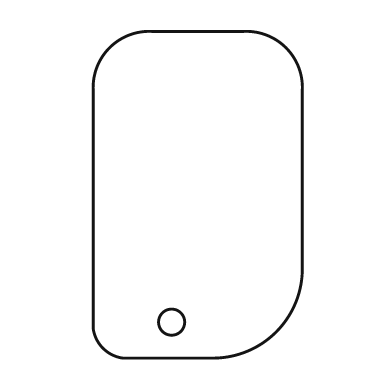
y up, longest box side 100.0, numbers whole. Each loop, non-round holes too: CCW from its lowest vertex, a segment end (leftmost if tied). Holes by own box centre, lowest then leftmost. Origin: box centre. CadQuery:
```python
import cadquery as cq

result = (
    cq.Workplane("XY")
    .moveTo(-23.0, -50.0)
    .lineTo(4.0, -50.0)
    .threePointArc((24.0, -42.0), (32.0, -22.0))
    .lineTo(32.0, 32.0)
    .threePointArc((27.0, 45.0), (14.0, 50.0))
    .lineTo(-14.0, 50.0)
    .threePointArc((-27.0, 45.0), (-32.0, 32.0))
    .lineTo(-32.0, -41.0)
    .threePointArc((-29.0, -47.0), (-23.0, -50.0))
    .close()
    .moveTo(-8.0, -39.0)
    .circle(4.0)
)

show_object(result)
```